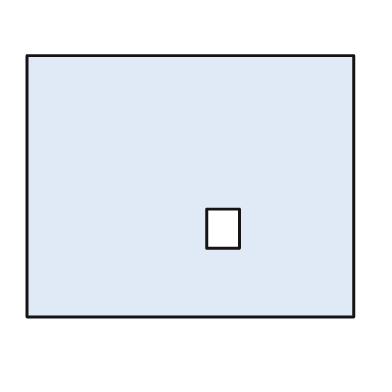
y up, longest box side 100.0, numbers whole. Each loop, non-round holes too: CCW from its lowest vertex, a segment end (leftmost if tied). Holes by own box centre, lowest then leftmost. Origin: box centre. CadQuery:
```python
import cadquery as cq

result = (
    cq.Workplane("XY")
    .moveTo(-50.0, -40.0)
    .lineTo(50.0, -40.0)
    .lineTo(50.0, 40.0)
    .lineTo(-50.0, 40.0)
    .close()
    .moveTo(5.0, -19.0)
    .lineTo(15.0, -19.0)
    .lineTo(15.0, -7.0)
    .lineTo(5.0, -7.0)
    .close()
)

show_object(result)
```